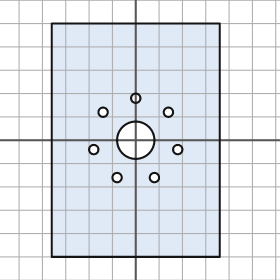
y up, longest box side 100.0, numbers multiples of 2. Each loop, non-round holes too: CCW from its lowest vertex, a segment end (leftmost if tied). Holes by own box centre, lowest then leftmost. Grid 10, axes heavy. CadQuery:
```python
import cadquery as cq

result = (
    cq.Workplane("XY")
    .moveTo(-36.0, -50.0)
    .lineTo(36.0, -50.0)
    .lineTo(36.0, 50.0)
    .lineTo(-36.0, 50.0)
    .close()
    .moveTo(-8.0, -16.0)
    .circle(2.0)
    .moveTo(8.0, -16.0)
    .circle(2.0)
    .moveTo(-18.0, -4.0)
    .circle(2.0)
    .moveTo(18.0, -4.0)
    .circle(2.0)
    .moveTo(0.0, 0.0)
    .circle(8.0)
    .moveTo(-14.0, 12.0)
    .circle(2.0)
    .moveTo(14.0, 12.0)
    .circle(2.0)
    .moveTo(0.0, 18.0)
    .circle(2.0)
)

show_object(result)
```